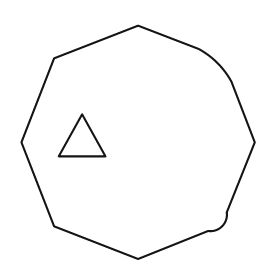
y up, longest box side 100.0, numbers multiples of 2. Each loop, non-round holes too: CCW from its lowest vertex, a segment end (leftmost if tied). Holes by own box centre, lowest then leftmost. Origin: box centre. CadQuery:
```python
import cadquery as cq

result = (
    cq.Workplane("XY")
    .moveTo(0.0, -50.0)
    .lineTo(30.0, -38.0)
    .threePointArc((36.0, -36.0), (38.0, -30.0))
    .lineTo(50.0, 0.0)
    .lineTo(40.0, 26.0)
    .threePointArc((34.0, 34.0), (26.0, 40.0))
    .lineTo(0.0, 50.0)
    .lineTo(-36.0, 36.0)
    .lineTo(-50.0, 0.0)
    .lineTo(-36.0, -36.0)
    .close()
    .moveTo(-34.0, -6.0)
    .lineTo(-14.0, -6.0)
    .lineTo(-24.0, 12.0)
    .close()
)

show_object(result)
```